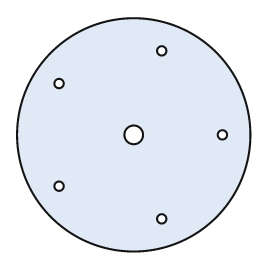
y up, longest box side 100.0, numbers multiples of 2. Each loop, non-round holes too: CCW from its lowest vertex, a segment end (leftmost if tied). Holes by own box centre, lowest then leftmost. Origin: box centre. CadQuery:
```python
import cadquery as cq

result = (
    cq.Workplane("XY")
    .moveTo(0.0, 0.0)
    .circle(50.0)
    .moveTo(12.0, -36.0)
    .circle(2.0)
    .moveTo(-32.0, -22.0)
    .circle(2.0)
    .moveTo(0.0, 0.0)
    .circle(4.0)
    .moveTo(38.0, 0.0)
    .circle(2.0)
    .moveTo(-32.0, 22.0)
    .circle(2.0)
    .moveTo(12.0, 36.0)
    .circle(2.0)
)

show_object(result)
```